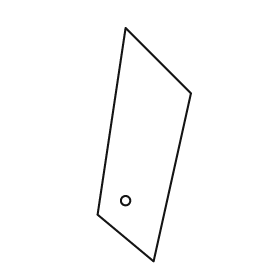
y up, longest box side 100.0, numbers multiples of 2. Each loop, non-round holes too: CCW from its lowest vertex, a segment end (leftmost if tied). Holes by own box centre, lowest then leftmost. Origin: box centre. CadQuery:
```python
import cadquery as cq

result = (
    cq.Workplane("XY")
    .moveTo(4.0, -50.0)
    .lineTo(20.0, 22.0)
    .lineTo(-8.0, 50.0)
    .lineTo(-20.0, -30.0)
    .close()
    .moveTo(-8.0, -24.0)
    .circle(2.0)
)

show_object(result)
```